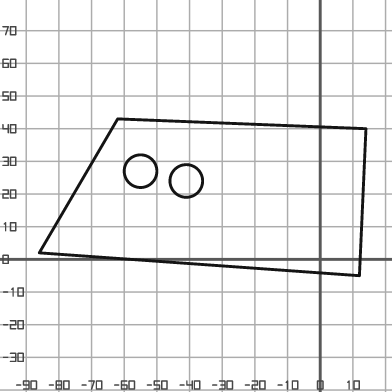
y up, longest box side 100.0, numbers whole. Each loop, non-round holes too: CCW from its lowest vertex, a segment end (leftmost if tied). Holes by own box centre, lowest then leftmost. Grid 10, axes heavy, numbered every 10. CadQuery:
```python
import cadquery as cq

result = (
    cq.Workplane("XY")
    .moveTo(12.0, -5.0)
    .lineTo(14.0, 40.0)
    .lineTo(-62.0, 43.0)
    .lineTo(-86.0, 2.0)
    .close()
    .moveTo(-41.0, 24.0)
    .circle(5.0)
    .moveTo(-55.0, 27.0)
    .circle(5.0)
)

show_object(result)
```